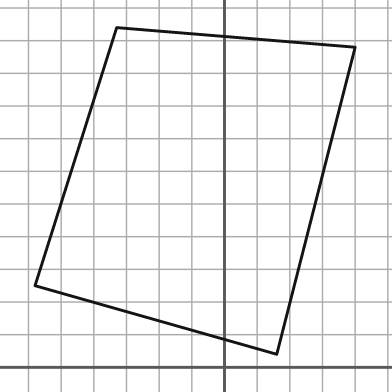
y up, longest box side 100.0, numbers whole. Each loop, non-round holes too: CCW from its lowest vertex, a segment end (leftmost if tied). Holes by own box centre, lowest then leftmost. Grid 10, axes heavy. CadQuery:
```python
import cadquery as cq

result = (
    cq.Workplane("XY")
    .moveTo(16.0, 4.0)
    .lineTo(40.0, 98.0)
    .lineTo(-33.0, 104.0)
    .lineTo(-58.0, 25.0)
    .close()
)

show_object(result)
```